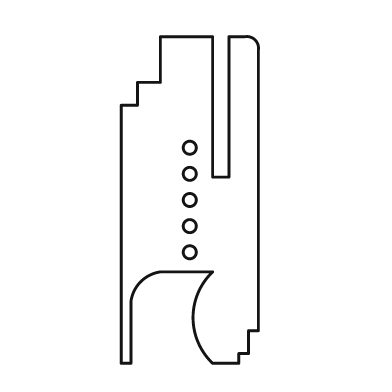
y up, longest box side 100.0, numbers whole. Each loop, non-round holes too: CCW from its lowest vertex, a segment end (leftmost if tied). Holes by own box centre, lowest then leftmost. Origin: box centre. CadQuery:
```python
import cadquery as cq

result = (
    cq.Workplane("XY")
    .moveTo(-21.0, -50.0)
    .lineTo(-18.0, -50.0)
    .lineTo(-18.0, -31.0)
    .threePointArc((-15.0, -25.0), (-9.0, -22.0))
    .lineTo(7.0, -22.0)
    .threePointArc((1.0, -36.0), (7.0, -50.0))
    .lineTo(15.0, -50.0)
    .lineTo(15.0, -47.0)
    .lineTo(18.0, -47.0)
    .lineTo(18.0, -40.0)
    .lineTo(21.0, -40.0)
    .lineTo(21.0, 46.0)
    .threePointArc((20.0, 49.0), (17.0, 50.0))
    .lineTo(12.0, 50.0)
    .lineTo(12.0, 7.0)
    .lineTo(7.0, 7.0)
    .lineTo(7.0, 50.0)
    .lineTo(-9.0, 50.0)
    .lineTo(-9.0, 36.0)
    .lineTo(-16.0, 36.0)
    .lineTo(-16.0, 29.0)
    .lineTo(-21.0, 29.0)
    .close()
    .moveTo(0.0, -16.0)
    .circle(2.0)
    .moveTo(0.0, -8.0)
    .circle(2.0)
    .moveTo(0.0, 0.0)
    .circle(2.0)
    .moveTo(0.0, 8.0)
    .circle(2.0)
    .moveTo(0.0, 16.0)
    .circle(2.0)
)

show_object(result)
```